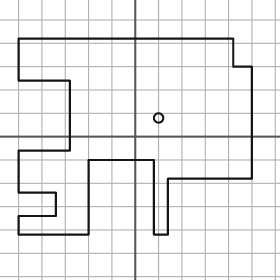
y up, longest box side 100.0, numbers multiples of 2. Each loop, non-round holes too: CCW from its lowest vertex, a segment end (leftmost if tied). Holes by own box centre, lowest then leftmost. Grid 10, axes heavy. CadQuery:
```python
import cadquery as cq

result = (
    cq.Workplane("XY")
    .moveTo(-50.0, -42.0)
    .lineTo(-20.0, -42.0)
    .lineTo(-20.0, -10.0)
    .lineTo(8.0, -10.0)
    .lineTo(8.0, -42.0)
    .lineTo(14.0, -42.0)
    .lineTo(14.0, -18.0)
    .lineTo(50.0, -18.0)
    .lineTo(50.0, 30.0)
    .lineTo(42.0, 30.0)
    .lineTo(42.0, 42.0)
    .lineTo(-50.0, 42.0)
    .lineTo(-50.0, 24.0)
    .lineTo(-28.0, 24.0)
    .lineTo(-28.0, -6.0)
    .lineTo(-50.0, -6.0)
    .lineTo(-50.0, -24.0)
    .lineTo(-34.0, -24.0)
    .lineTo(-34.0, -34.0)
    .lineTo(-50.0, -34.0)
    .close()
    .moveTo(10.0, 8.0)
    .circle(2.0)
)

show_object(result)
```